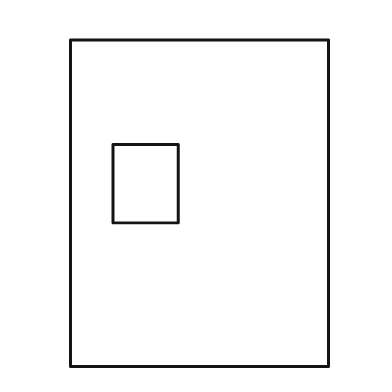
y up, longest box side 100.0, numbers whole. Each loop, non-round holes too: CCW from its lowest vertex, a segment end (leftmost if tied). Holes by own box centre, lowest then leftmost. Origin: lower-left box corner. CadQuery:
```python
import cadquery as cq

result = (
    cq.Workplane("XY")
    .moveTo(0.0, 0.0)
    .lineTo(79.0, 0.0)
    .lineTo(79.0, 100.0)
    .lineTo(0.0, 100.0)
    .close()
    .moveTo(13.0, 44.0)
    .lineTo(33.0, 44.0)
    .lineTo(33.0, 68.0)
    .lineTo(13.0, 68.0)
    .close()
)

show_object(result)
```